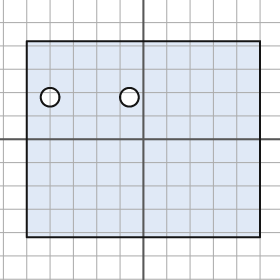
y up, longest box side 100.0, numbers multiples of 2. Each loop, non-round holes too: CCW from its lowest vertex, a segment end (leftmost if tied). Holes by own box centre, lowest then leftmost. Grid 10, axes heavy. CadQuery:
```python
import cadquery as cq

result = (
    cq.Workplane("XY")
    .moveTo(-50.0, -42.0)
    .lineTo(50.0, -42.0)
    .lineTo(50.0, 42.0)
    .lineTo(-50.0, 42.0)
    .close()
    .moveTo(-40.0, 18.0)
    .circle(4.0)
    .moveTo(-6.0, 18.0)
    .circle(4.0)
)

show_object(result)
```